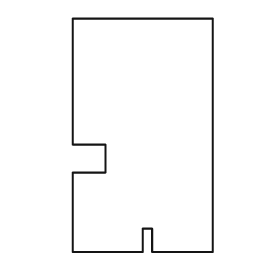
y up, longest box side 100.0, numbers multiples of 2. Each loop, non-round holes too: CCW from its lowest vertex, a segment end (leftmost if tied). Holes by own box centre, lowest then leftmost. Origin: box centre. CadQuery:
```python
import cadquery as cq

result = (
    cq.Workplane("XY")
    .moveTo(-30.0, -50.0)
    .lineTo(0.0, -50.0)
    .lineTo(0.0, -40.0)
    .lineTo(4.0, -40.0)
    .lineTo(4.0, -50.0)
    .lineTo(30.0, -50.0)
    .lineTo(30.0, 50.0)
    .lineTo(-30.0, 50.0)
    .lineTo(-30.0, -4.0)
    .lineTo(-16.0, -4.0)
    .lineTo(-16.0, -16.0)
    .lineTo(-30.0, -16.0)
    .close()
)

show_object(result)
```